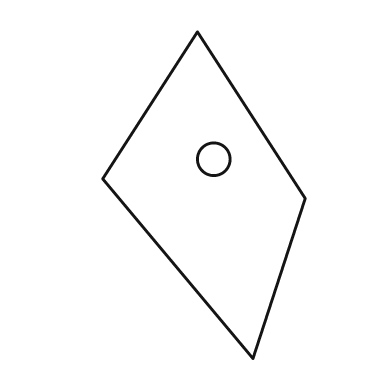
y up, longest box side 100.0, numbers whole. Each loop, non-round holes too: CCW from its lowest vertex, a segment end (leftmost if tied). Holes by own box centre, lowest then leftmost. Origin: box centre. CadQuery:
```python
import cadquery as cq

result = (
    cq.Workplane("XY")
    .moveTo(15.0, -50.0)
    .lineTo(31.0, -1.0)
    .lineTo(-2.0, 50.0)
    .lineTo(-31.0, 5.0)
    .close()
    .moveTo(3.0, 11.0)
    .circle(5.0)
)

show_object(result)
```